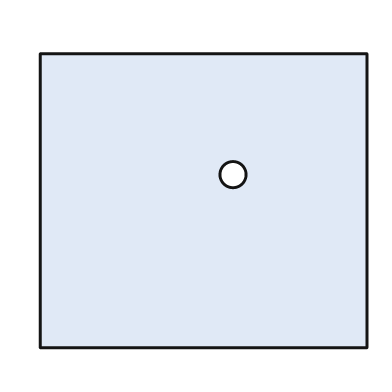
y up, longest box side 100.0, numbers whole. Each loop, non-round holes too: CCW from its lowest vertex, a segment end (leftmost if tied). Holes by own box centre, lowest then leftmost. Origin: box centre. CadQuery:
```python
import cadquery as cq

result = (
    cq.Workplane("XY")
    .moveTo(-50.0, -45.0)
    .lineTo(50.0, -45.0)
    .lineTo(50.0, 45.0)
    .lineTo(-50.0, 45.0)
    .close()
    .moveTo(9.0, 8.0)
    .circle(4.0)
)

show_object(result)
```